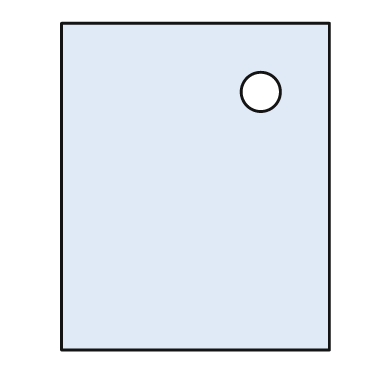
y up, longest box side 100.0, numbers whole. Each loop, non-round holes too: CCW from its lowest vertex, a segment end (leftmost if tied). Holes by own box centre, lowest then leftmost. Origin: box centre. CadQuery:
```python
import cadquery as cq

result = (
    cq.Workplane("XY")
    .moveTo(-41.0, -50.0)
    .lineTo(41.0, -50.0)
    .lineTo(41.0, 50.0)
    .lineTo(-41.0, 50.0)
    .close()
    .moveTo(20.0, 29.0)
    .circle(6.0)
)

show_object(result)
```